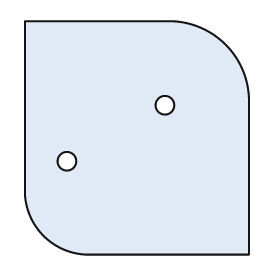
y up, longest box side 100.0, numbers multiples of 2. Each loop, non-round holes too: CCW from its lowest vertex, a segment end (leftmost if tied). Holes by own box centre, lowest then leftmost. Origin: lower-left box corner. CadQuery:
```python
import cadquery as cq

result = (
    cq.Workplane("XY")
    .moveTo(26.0, 0.0)
    .lineTo(96.0, 0.0)
    .lineTo(96.0, 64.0)
    .threePointArc((86.0, 90.0), (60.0, 100.0))
    .lineTo(0.0, 100.0)
    .lineTo(0.0, 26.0)
    .threePointArc((8.0, 8.0), (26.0, 0.0))
    .close()
    .moveTo(18.0, 40.0)
    .circle(4.0)
    .moveTo(60.0, 64.0)
    .circle(4.0)
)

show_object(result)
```